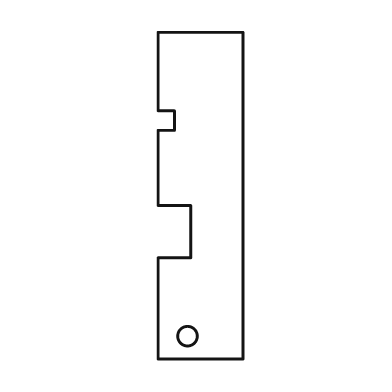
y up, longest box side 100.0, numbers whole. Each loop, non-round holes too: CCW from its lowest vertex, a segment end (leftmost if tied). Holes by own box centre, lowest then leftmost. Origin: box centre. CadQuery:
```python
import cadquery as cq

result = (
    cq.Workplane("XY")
    .moveTo(-13.0, -50.0)
    .lineTo(13.0, -50.0)
    .lineTo(13.0, 50.0)
    .lineTo(-13.0, 50.0)
    .lineTo(-13.0, 26.0)
    .lineTo(-8.0, 26.0)
    .lineTo(-8.0, 20.0)
    .lineTo(-13.0, 20.0)
    .lineTo(-13.0, -3.0)
    .lineTo(-3.0, -3.0)
    .lineTo(-3.0, -19.0)
    .lineTo(-13.0, -19.0)
    .close()
    .moveTo(-4.0, -43.0)
    .circle(3.0)
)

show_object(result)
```